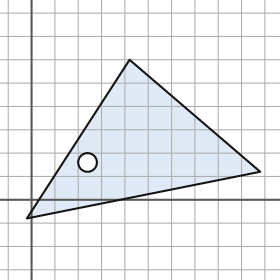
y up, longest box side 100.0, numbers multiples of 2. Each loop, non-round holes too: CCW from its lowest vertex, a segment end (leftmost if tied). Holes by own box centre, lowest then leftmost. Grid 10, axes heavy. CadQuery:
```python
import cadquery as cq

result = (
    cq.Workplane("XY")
    .moveTo(-2.0, -8.0)
    .lineTo(98.0, 12.0)
    .lineTo(42.0, 60.0)
    .close()
    .moveTo(24.0, 16.0)
    .circle(4.0)
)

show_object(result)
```